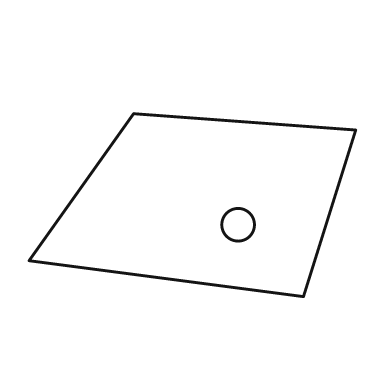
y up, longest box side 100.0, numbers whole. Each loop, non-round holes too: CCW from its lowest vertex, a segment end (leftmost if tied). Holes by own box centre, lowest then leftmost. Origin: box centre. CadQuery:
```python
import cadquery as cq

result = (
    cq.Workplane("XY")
    .moveTo(34.0, -28.0)
    .lineTo(50.0, 23.0)
    .lineTo(-18.0, 28.0)
    .lineTo(-50.0, -17.0)
    .close()
    .moveTo(14.0, -6.0)
    .circle(5.0)
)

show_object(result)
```